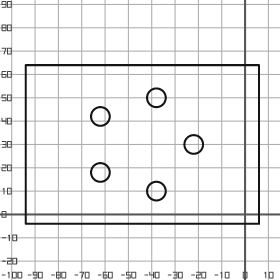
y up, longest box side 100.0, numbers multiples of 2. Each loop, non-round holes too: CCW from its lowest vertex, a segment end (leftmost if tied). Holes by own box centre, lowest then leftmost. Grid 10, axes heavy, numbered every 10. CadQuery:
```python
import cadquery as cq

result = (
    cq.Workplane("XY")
    .moveTo(-94.0, -4.0)
    .lineTo(6.0, -4.0)
    .lineTo(6.0, 64.0)
    .lineTo(-94.0, 64.0)
    .close()
    .moveTo(-38.0, 10.0)
    .circle(4.0)
    .moveTo(-62.0, 18.0)
    .circle(4.0)
    .moveTo(-22.0, 30.0)
    .circle(4.0)
    .moveTo(-62.0, 42.0)
    .circle(4.0)
    .moveTo(-38.0, 50.0)
    .circle(4.0)
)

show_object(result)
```